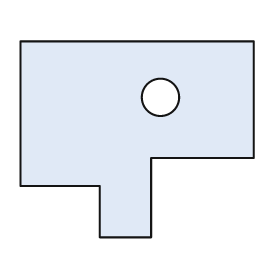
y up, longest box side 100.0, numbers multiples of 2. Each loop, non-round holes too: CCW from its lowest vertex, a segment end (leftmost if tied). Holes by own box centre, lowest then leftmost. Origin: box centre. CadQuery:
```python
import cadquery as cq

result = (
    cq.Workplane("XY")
    .moveTo(-16.0, -42.0)
    .lineTo(6.0, -42.0)
    .lineTo(6.0, -8.0)
    .lineTo(50.0, -8.0)
    .lineTo(50.0, 42.0)
    .lineTo(-50.0, 42.0)
    .lineTo(-50.0, -20.0)
    .lineTo(-16.0, -20.0)
    .close()
    .moveTo(10.0, 18.0)
    .circle(8.0)
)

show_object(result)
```